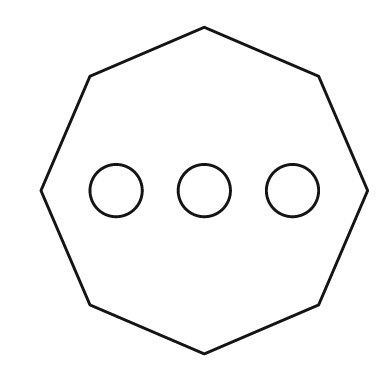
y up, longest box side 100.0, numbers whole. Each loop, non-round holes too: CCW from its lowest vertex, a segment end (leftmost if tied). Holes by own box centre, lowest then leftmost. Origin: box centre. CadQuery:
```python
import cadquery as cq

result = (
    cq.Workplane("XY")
    .moveTo(0.0, -50.0)
    .lineTo(35.0, -35.0)
    .lineTo(50.0, 0.0)
    .lineTo(35.0, 35.0)
    .lineTo(0.0, 50.0)
    .lineTo(-35.0, 35.0)
    .lineTo(-50.0, 0.0)
    .lineTo(-35.0, -35.0)
    .close()
    .moveTo(-27.0, 0.0)
    .circle(8.0)
    .moveTo(0.0, 0.0)
    .circle(8.0)
    .moveTo(27.0, 0.0)
    .circle(8.0)
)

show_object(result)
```